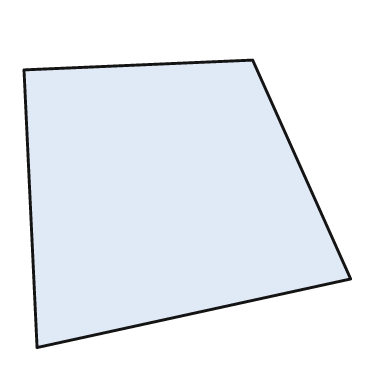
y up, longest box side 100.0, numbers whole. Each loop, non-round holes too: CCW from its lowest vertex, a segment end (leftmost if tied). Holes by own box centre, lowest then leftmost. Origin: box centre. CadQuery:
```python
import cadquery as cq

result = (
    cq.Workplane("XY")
    .moveTo(-46.0, -44.0)
    .lineTo(50.0, -23.0)
    .lineTo(20.0, 44.0)
    .lineTo(-50.0, 41.0)
    .close()
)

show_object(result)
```